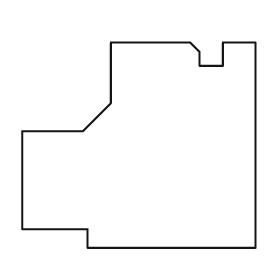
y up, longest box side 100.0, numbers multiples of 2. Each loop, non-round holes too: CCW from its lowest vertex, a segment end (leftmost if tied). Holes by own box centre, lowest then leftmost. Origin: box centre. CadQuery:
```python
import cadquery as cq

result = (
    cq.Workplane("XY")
    .moveTo(-22.0, -44.0)
    .lineTo(50.0, -44.0)
    .lineTo(50.0, 44.0)
    .lineTo(36.0, 44.0)
    .lineTo(36.0, 34.0)
    .lineTo(26.0, 34.0)
    .lineTo(26.0, 40.0)
    .lineTo(22.0, 44.0)
    .lineTo(-12.0, 44.0)
    .lineTo(-12.0, 18.0)
    .lineTo(-24.0, 6.0)
    .lineTo(-50.0, 6.0)
    .lineTo(-50.0, -36.0)
    .lineTo(-22.0, -36.0)
    .close()
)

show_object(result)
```